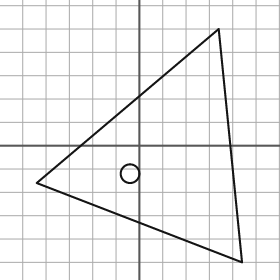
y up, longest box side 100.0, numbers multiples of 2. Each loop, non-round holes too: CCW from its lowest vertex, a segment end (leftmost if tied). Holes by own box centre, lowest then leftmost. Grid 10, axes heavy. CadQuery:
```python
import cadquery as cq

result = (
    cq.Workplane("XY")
    .moveTo(44.0, -50.0)
    .lineTo(34.0, 50.0)
    .lineTo(-44.0, -16.0)
    .close()
    .moveTo(-4.0, -12.0)
    .circle(4.0)
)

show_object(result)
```